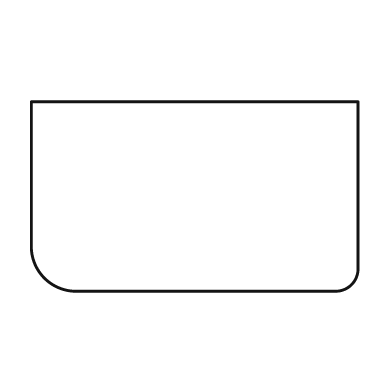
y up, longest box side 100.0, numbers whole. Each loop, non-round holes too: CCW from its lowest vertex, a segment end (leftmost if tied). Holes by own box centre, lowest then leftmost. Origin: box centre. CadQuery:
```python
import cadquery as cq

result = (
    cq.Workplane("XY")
    .moveTo(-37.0, -29.0)
    .lineTo(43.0, -29.0)
    .threePointArc((48.0, -27.0), (50.0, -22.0))
    .lineTo(50.0, 29.0)
    .lineTo(-50.0, 29.0)
    .lineTo(-50.0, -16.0)
    .threePointArc((-46.0, -25.0), (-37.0, -29.0))
    .close()
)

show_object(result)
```